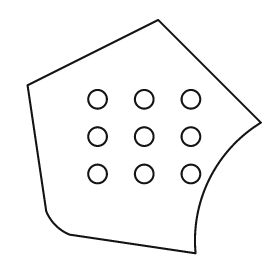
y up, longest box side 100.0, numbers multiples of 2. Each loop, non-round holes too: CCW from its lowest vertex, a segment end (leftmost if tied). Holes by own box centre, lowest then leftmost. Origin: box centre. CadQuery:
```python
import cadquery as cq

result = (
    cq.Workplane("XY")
    .moveTo(22.0, -50.0)
    .threePointArc((28.0, -18.0), (50.0, 6.0))
    .lineTo(6.0, 50.0)
    .lineTo(-50.0, 22.0)
    .lineTo(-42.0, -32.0)
    .threePointArc((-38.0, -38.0), (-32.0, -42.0))
    .close()
    .moveTo(-20.0, -16.0)
    .circle(4.0)
    .moveTo(0.0, -16.0)
    .circle(4.0)
    .moveTo(20.0, -16.0)
    .circle(4.0)
    .moveTo(-20.0, 0.0)
    .circle(4.0)
    .moveTo(0.0, 0.0)
    .circle(4.0)
    .moveTo(20.0, 0.0)
    .circle(4.0)
    .moveTo(-20.0, 16.0)
    .circle(4.0)
    .moveTo(0.0, 16.0)
    .circle(4.0)
    .moveTo(20.0, 16.0)
    .circle(4.0)
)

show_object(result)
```